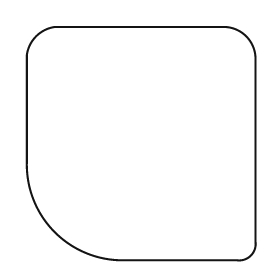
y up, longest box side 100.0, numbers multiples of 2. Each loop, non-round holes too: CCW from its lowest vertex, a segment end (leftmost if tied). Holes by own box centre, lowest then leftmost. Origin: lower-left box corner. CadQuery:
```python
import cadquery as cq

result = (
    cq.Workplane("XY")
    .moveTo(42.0, 0.0)
    .lineTo(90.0, 0.0)
    .threePointArc((96.0, 2.0), (98.0, 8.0))
    .lineTo(98.0, 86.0)
    .threePointArc((94.0, 96.0), (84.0, 100.0))
    .lineTo(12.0, 100.0)
    .threePointArc((4.0, 96.0), (0.0, 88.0))
    .lineTo(0.0, 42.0)
    .threePointArc((12.0, 12.0), (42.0, 0.0))
    .close()
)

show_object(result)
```